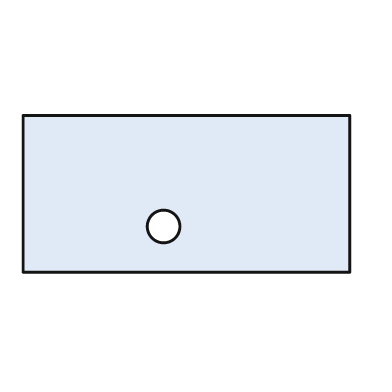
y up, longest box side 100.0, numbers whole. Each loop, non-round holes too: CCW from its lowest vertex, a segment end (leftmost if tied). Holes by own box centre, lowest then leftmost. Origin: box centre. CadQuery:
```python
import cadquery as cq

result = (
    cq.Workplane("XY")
    .moveTo(-50.0, -24.0)
    .lineTo(50.0, -24.0)
    .lineTo(50.0, 24.0)
    .lineTo(-50.0, 24.0)
    .close()
    .moveTo(-7.0, -10.0)
    .circle(5.0)
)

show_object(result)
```